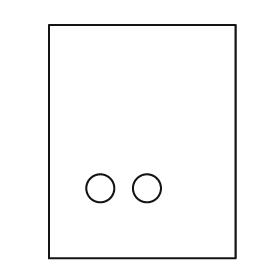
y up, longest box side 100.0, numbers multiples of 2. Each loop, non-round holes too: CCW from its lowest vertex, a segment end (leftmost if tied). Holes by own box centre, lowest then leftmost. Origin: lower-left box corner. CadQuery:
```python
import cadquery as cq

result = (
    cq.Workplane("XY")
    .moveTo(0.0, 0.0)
    .lineTo(80.0, 0.0)
    .lineTo(80.0, 100.0)
    .lineTo(0.0, 100.0)
    .close()
    .moveTo(22.0, 30.0)
    .circle(6.0)
    .moveTo(42.0, 30.0)
    .circle(6.0)
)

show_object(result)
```